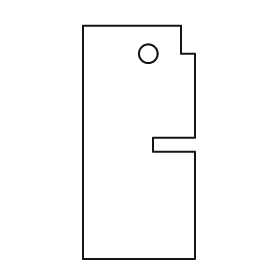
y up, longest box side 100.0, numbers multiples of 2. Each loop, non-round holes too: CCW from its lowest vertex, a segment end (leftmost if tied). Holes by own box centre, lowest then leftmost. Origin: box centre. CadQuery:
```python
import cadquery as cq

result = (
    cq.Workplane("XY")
    .moveTo(-24.0, -50.0)
    .lineTo(24.0, -50.0)
    .lineTo(24.0, -4.0)
    .lineTo(6.0, -4.0)
    .lineTo(6.0, 2.0)
    .lineTo(24.0, 2.0)
    .lineTo(24.0, 38.0)
    .lineTo(18.0, 38.0)
    .lineTo(18.0, 50.0)
    .lineTo(-24.0, 50.0)
    .close()
    .moveTo(4.0, 38.0)
    .circle(4.0)
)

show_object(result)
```